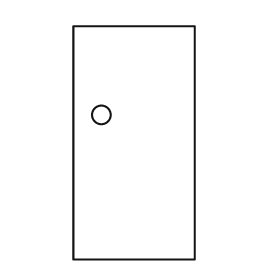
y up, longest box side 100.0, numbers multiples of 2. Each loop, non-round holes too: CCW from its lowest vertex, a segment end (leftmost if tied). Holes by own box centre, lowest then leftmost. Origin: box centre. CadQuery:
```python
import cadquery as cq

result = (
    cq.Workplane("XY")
    .moveTo(-26.0, -50.0)
    .lineTo(26.0, -50.0)
    .lineTo(26.0, 50.0)
    .lineTo(-26.0, 50.0)
    .close()
    .moveTo(-14.0, 12.0)
    .circle(4.0)
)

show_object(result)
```